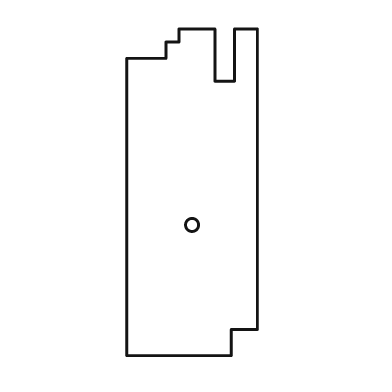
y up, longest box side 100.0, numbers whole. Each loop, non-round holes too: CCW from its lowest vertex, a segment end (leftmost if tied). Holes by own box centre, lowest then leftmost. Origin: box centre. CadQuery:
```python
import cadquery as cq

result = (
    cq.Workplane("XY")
    .moveTo(-20.0, -50.0)
    .lineTo(12.0, -50.0)
    .lineTo(12.0, -42.0)
    .lineTo(20.0, -42.0)
    .lineTo(20.0, 50.0)
    .lineTo(13.0, 50.0)
    .lineTo(13.0, 34.0)
    .lineTo(7.0, 34.0)
    .lineTo(7.0, 50.0)
    .lineTo(-4.0, 50.0)
    .lineTo(-4.0, 46.0)
    .lineTo(-8.0, 46.0)
    .lineTo(-8.0, 41.0)
    .lineTo(-20.0, 41.0)
    .close()
    .moveTo(0.0, -10.0)
    .circle(2.0)
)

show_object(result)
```